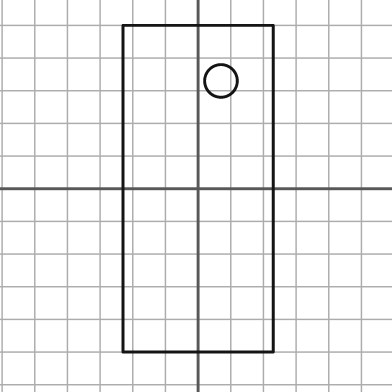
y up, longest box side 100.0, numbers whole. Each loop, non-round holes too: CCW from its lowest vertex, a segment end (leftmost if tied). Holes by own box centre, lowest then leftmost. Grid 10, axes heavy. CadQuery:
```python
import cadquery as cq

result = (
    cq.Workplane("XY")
    .moveTo(-23.0, -50.0)
    .lineTo(23.0, -50.0)
    .lineTo(23.0, 50.0)
    .lineTo(-23.0, 50.0)
    .close()
    .moveTo(7.0, 33.0)
    .circle(5.0)
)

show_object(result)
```